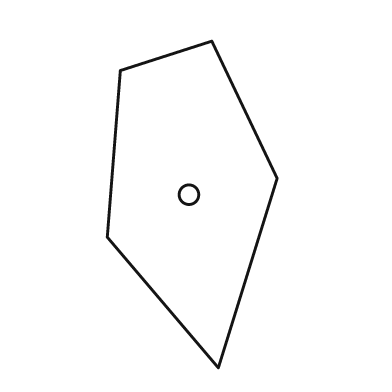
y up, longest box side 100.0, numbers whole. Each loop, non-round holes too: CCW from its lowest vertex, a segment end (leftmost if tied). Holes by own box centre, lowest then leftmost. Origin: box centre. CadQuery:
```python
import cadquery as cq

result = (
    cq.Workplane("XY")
    .moveTo(8.0, -50.0)
    .lineTo(26.0, 8.0)
    .lineTo(6.0, 50.0)
    .lineTo(-22.0, 41.0)
    .lineTo(-26.0, -10.0)
    .close()
    .moveTo(-1.0, 3.0)
    .circle(3.0)
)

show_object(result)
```